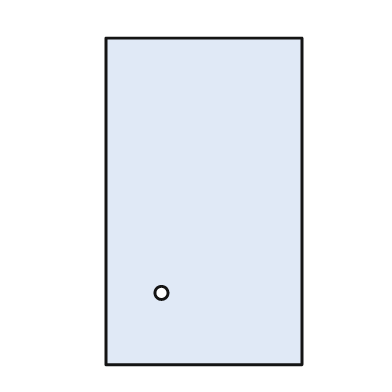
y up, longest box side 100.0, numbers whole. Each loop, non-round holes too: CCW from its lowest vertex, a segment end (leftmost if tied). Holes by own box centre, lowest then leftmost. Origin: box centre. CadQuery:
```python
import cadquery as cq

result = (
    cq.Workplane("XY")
    .moveTo(-30.0, -50.0)
    .lineTo(30.0, -50.0)
    .lineTo(30.0, 50.0)
    .lineTo(-30.0, 50.0)
    .close()
    .moveTo(-13.0, -28.0)
    .circle(2.0)
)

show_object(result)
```